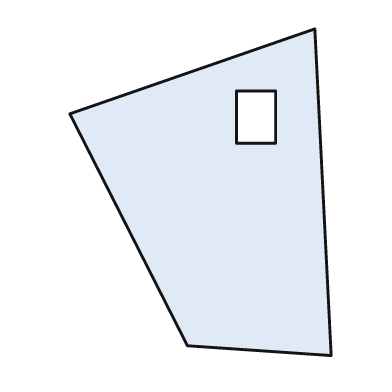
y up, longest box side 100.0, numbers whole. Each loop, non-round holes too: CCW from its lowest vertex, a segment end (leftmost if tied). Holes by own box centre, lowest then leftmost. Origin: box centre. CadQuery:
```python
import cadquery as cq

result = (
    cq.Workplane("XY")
    .moveTo(40.0, -50.0)
    .lineTo(35.0, 50.0)
    .lineTo(-40.0, 24.0)
    .lineTo(-4.0, -47.0)
    .close()
    .moveTo(11.0, 15.0)
    .lineTo(23.0, 15.0)
    .lineTo(23.0, 31.0)
    .lineTo(11.0, 31.0)
    .close()
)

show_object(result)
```